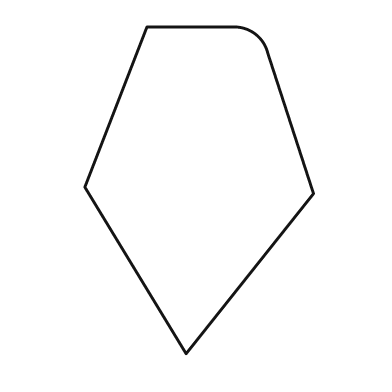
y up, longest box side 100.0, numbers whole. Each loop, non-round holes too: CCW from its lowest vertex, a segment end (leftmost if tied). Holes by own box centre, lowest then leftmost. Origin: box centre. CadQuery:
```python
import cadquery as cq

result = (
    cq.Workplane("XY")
    .moveTo(-4.0, -50.0)
    .lineTo(35.0, -1.0)
    .lineTo(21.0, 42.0)
    .threePointArc((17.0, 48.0), (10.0, 50.0))
    .lineTo(-16.0, 50.0)
    .lineTo(-35.0, 1.0)
    .close()
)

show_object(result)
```